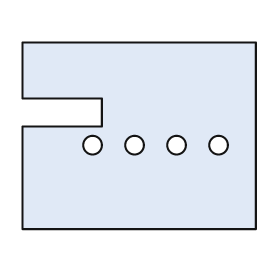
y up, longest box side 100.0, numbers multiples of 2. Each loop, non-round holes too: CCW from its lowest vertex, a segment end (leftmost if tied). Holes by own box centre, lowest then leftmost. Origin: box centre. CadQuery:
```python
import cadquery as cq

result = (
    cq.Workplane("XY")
    .moveTo(-50.0, -40.0)
    .lineTo(50.0, -40.0)
    .lineTo(50.0, 40.0)
    .lineTo(-50.0, 40.0)
    .lineTo(-50.0, 16.0)
    .lineTo(-16.0, 16.0)
    .lineTo(-16.0, 4.0)
    .lineTo(-50.0, 4.0)
    .close()
    .moveTo(-20.0, -4.0)
    .circle(4.0)
    .moveTo(-2.0, -4.0)
    .circle(4.0)
    .moveTo(16.0, -4.0)
    .circle(4.0)
    .moveTo(34.0, -4.0)
    .circle(4.0)
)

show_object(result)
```